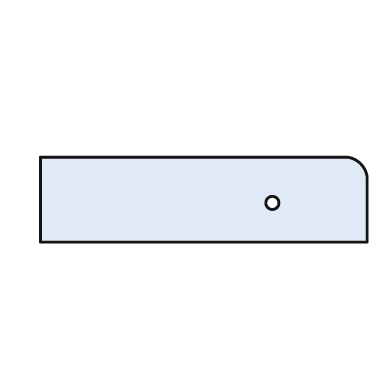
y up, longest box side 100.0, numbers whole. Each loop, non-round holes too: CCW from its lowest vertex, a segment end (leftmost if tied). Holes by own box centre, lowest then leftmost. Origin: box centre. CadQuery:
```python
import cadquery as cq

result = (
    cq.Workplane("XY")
    .moveTo(-50.0, -13.0)
    .lineTo(50.0, -13.0)
    .lineTo(50.0, 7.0)
    .threePointArc((48.0, 11.0), (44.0, 13.0))
    .lineTo(-50.0, 13.0)
    .close()
    .moveTo(21.0, -1.0)
    .circle(2.0)
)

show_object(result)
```